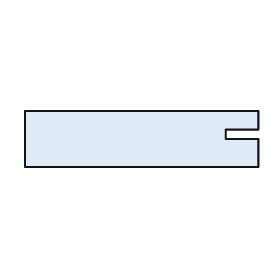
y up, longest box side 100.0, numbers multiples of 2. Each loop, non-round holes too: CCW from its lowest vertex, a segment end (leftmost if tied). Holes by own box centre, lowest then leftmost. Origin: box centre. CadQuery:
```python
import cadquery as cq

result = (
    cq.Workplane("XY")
    .moveTo(-50.0, -12.0)
    .lineTo(50.0, -12.0)
    .lineTo(50.0, 0.0)
    .lineTo(36.0, 0.0)
    .lineTo(36.0, 4.0)
    .lineTo(50.0, 4.0)
    .lineTo(50.0, 12.0)
    .lineTo(-50.0, 12.0)
    .close()
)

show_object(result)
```